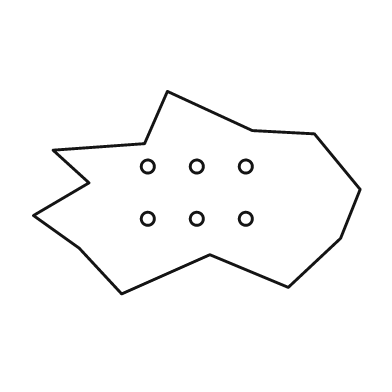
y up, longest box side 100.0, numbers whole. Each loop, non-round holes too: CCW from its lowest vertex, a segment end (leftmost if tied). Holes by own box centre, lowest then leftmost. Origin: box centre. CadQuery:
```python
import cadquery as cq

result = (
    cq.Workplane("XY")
    .moveTo(-23.0, -31.0)
    .lineTo(4.0, -19.0)
    .lineTo(28.0, -29.0)
    .lineTo(44.0, -14.0)
    .lineTo(50.0, 1.0)
    .lineTo(36.0, 18.0)
    .lineTo(17.0, 19.0)
    .lineTo(-9.0, 31.0)
    .lineTo(-16.0, 15.0)
    .lineTo(-44.0, 13.0)
    .lineTo(-33.0, 3.0)
    .lineTo(-50.0, -7.0)
    .lineTo(-36.0, -17.0)
    .close()
    .moveTo(-15.0, -8.0)
    .circle(2.0)
    .moveTo(0.0, -8.0)
    .circle(2.0)
    .moveTo(15.0, -8.0)
    .circle(2.0)
    .moveTo(-15.0, 8.0)
    .circle(2.0)
    .moveTo(0.0, 8.0)
    .circle(2.0)
    .moveTo(15.0, 8.0)
    .circle(2.0)
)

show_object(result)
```